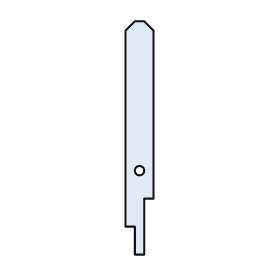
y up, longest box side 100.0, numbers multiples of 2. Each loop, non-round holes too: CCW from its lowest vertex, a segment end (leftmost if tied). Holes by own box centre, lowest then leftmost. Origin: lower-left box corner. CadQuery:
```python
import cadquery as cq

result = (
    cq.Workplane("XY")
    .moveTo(4.0, 0.0)
    .lineTo(8.0, 0.0)
    .lineTo(8.0, 24.0)
    .lineTo(12.0, 24.0)
    .lineTo(12.0, 96.0)
    .lineTo(8.0, 100.0)
    .lineTo(4.0, 100.0)
    .lineTo(0.0, 96.0)
    .lineTo(0.0, 12.0)
    .lineTo(4.0, 12.0)
    .close()
    .moveTo(6.0, 36.0)
    .circle(2.0)
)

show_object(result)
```